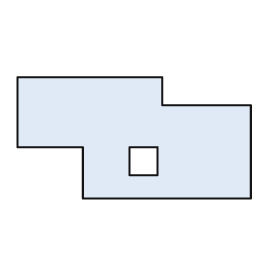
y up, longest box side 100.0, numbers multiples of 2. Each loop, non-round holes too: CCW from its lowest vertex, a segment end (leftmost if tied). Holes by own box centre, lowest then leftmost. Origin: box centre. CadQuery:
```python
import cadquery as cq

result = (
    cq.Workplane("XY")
    .moveTo(-22.0, -26.0)
    .lineTo(50.0, -26.0)
    .lineTo(50.0, 14.0)
    .lineTo(12.0, 14.0)
    .lineTo(12.0, 26.0)
    .lineTo(-50.0, 26.0)
    .lineTo(-50.0, -4.0)
    .lineTo(-22.0, -4.0)
    .close()
    .moveTo(-2.0, -16.0)
    .lineTo(10.0, -16.0)
    .lineTo(10.0, -4.0)
    .lineTo(-2.0, -4.0)
    .close()
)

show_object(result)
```